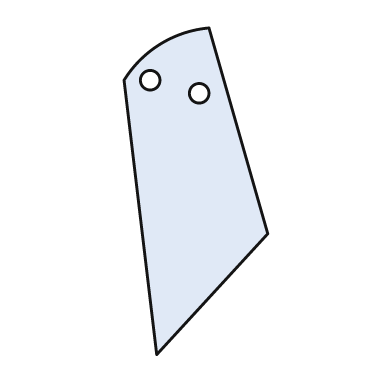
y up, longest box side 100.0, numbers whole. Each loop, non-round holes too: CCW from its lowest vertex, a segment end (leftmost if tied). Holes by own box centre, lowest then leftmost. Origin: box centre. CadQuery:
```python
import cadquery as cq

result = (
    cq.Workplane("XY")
    .moveTo(-12.0, -50.0)
    .lineTo(22.0, -13.0)
    .lineTo(4.0, 50.0)
    .threePointArc((-11.0, 45.0), (-22.0, 34.0))
    .close()
    .moveTo(1.0, 30.0)
    .circle(3.0)
    .moveTo(-14.0, 34.0)
    .circle(3.0)
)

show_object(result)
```